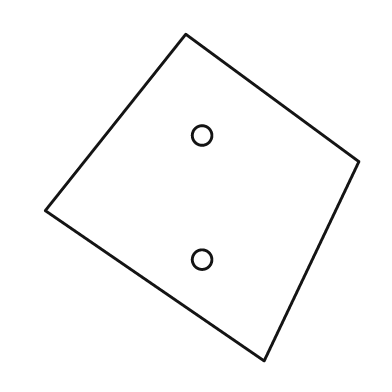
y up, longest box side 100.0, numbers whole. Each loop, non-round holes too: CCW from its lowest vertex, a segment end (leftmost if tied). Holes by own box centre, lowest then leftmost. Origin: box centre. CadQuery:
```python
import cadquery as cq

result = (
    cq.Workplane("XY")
    .moveTo(19.0, -50.0)
    .lineTo(48.0, 11.0)
    .lineTo(-5.0, 50.0)
    .lineTo(-48.0, -4.0)
    .close()
    .moveTo(0.0, -19.0)
    .circle(3.0)
    .moveTo(0.0, 19.0)
    .circle(3.0)
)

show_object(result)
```